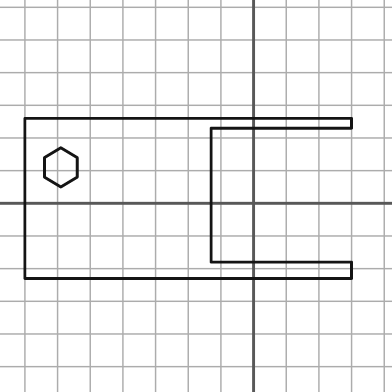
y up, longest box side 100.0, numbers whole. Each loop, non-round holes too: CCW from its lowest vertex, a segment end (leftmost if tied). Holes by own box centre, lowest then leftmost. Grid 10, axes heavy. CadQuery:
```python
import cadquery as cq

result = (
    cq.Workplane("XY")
    .moveTo(-70.0, -23.0)
    .lineTo(30.0, -23.0)
    .lineTo(30.0, -18.0)
    .lineTo(-13.0, -18.0)
    .lineTo(-13.0, 23.0)
    .lineTo(30.0, 23.0)
    .lineTo(30.0, 26.0)
    .lineTo(-70.0, 26.0)
    .close()
    .moveTo(-59.0, 5.0)
    .lineTo(-54.0, 8.0)
    .lineTo(-54.0, 14.0)
    .lineTo(-59.0, 17.0)
    .lineTo(-64.0, 14.0)
    .lineTo(-64.0, 8.0)
    .close()
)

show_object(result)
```